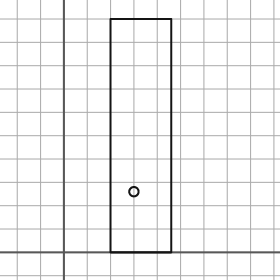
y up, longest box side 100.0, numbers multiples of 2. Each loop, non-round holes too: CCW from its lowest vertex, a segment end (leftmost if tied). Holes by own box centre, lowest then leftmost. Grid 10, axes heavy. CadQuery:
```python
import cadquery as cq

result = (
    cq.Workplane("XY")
    .moveTo(20.0, 0.0)
    .lineTo(46.0, 0.0)
    .lineTo(46.0, 100.0)
    .lineTo(20.0, 100.0)
    .close()
    .moveTo(30.0, 26.0)
    .circle(2.0)
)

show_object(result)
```